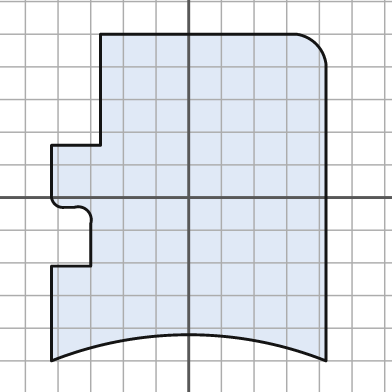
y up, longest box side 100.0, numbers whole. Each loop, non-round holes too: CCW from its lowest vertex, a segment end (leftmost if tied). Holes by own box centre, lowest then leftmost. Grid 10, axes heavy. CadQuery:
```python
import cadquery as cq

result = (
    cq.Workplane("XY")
    .moveTo(-42.0, -50.0)
    .threePointArc((0.0, -42.0), (42.0, -50.0))
    .lineTo(42.0, 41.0)
    .threePointArc((39.0, 47.0), (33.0, 50.0))
    .lineTo(-27.0, 50.0)
    .lineTo(-27.0, 16.0)
    .lineTo(-42.0, 16.0)
    .lineTo(-42.0, 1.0)
    .threePointArc((-41.0, -2.0), (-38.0, -3.0))
    .lineTo(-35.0, -3.0)
    .threePointArc((-31.0, -4.0), (-30.0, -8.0))
    .lineTo(-30.0, -21.0)
    .lineTo(-42.0, -21.0)
    .close()
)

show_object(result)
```